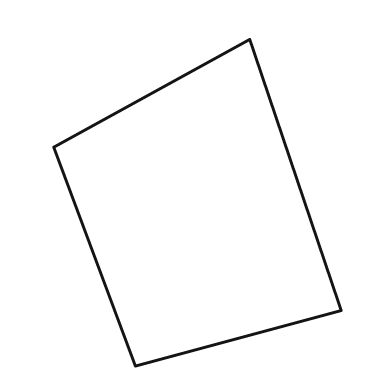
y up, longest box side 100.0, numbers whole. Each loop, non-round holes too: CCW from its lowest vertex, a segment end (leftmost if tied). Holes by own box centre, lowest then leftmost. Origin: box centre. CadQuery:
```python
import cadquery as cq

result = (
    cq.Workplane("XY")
    .moveTo(-19.0, -50.0)
    .lineTo(44.0, -33.0)
    .lineTo(16.0, 50.0)
    .lineTo(-44.0, 17.0)
    .close()
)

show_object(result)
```